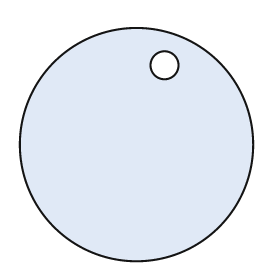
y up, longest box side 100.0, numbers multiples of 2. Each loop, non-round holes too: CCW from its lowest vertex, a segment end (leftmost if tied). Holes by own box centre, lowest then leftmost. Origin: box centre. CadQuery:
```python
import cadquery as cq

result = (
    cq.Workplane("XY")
    .moveTo(0.0, 0.0)
    .circle(50.0)
    .moveTo(12.0, 34.0)
    .circle(6.0)
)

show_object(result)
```